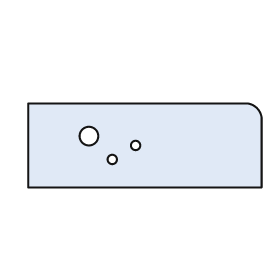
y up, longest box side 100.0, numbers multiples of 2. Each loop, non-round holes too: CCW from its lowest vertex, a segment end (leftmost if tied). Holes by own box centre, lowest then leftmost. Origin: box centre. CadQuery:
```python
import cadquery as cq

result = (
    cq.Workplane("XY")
    .moveTo(-50.0, -18.0)
    .lineTo(50.0, -18.0)
    .lineTo(50.0, 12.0)
    .threePointArc((48.0, 16.0), (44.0, 18.0))
    .lineTo(-50.0, 18.0)
    .close()
    .moveTo(-14.0, -6.0)
    .circle(2.0)
    .moveTo(-4.0, 0.0)
    .circle(2.0)
    .moveTo(-24.0, 4.0)
    .circle(4.0)
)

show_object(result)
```